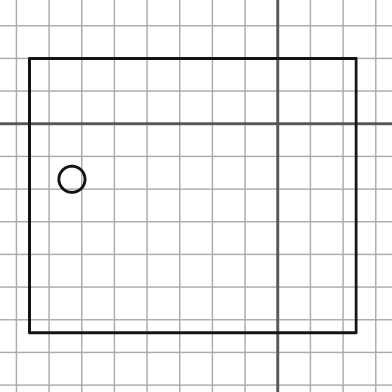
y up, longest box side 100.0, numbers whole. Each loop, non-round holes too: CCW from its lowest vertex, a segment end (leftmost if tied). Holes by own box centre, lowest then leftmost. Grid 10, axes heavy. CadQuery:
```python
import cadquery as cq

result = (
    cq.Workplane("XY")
    .moveTo(-76.0, -64.0)
    .lineTo(24.0, -64.0)
    .lineTo(24.0, 20.0)
    .lineTo(-76.0, 20.0)
    .close()
    .moveTo(-63.0, -17.0)
    .circle(4.0)
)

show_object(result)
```